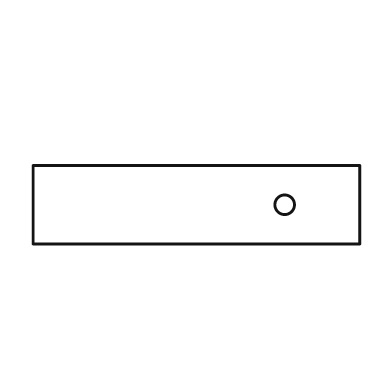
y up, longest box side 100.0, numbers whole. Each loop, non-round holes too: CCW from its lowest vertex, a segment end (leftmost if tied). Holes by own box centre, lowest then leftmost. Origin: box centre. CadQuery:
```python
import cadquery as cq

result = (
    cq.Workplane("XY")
    .moveTo(-50.0, -12.0)
    .lineTo(50.0, -12.0)
    .lineTo(50.0, 12.0)
    .lineTo(-50.0, 12.0)
    .close()
    .moveTo(27.0, 0.0)
    .circle(3.0)
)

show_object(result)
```